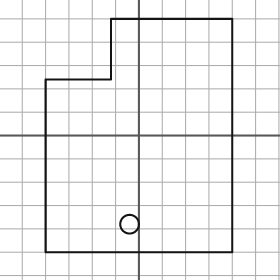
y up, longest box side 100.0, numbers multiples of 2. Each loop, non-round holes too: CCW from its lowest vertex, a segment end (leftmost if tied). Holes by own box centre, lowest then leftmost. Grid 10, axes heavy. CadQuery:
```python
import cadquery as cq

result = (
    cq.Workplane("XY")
    .moveTo(-40.0, -50.0)
    .lineTo(40.0, -50.0)
    .lineTo(40.0, 50.0)
    .lineTo(-12.0, 50.0)
    .lineTo(-12.0, 24.0)
    .lineTo(-40.0, 24.0)
    .close()
    .moveTo(-4.0, -38.0)
    .circle(4.0)
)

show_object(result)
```